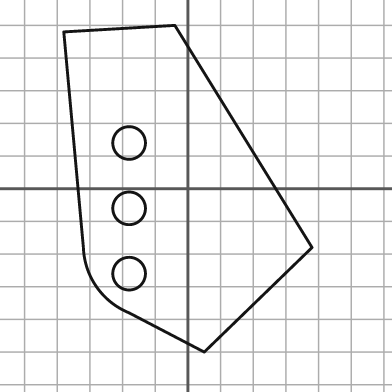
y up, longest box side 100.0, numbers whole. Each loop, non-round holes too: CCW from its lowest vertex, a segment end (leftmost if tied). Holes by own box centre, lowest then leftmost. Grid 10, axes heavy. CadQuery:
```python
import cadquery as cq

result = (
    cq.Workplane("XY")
    .moveTo(5.0, -50.0)
    .lineTo(38.0, -18.0)
    .lineTo(-4.0, 50.0)
    .lineTo(-38.0, 48.0)
    .lineTo(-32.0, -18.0)
    .threePointArc((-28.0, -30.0), (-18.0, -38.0))
    .close()
    .moveTo(-18.0, -26.0)
    .circle(5.0)
    .moveTo(-18.0, -6.0)
    .circle(5.0)
    .moveTo(-18.0, 14.0)
    .circle(5.0)
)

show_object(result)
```